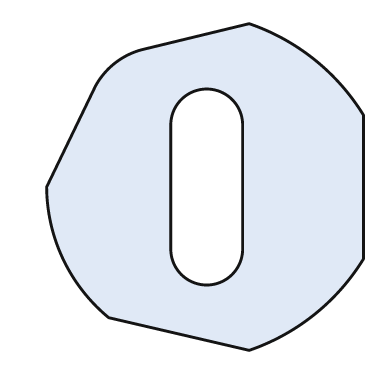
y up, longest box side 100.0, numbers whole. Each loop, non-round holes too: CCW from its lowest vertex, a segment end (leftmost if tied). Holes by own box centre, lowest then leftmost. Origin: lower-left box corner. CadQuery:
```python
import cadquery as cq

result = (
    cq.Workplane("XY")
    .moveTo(62.0, 0.0)
    .threePointArc((82.0, 11.0), (97.0, 28.0))
    .lineTo(97.0, 72.0)
    .threePointArc((82.0, 89.0), (62.0, 100.0))
    .lineTo(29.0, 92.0)
    .threePointArc((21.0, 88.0), (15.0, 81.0))
    .lineTo(0.0, 50.0)
    .threePointArc((5.0, 28.0), (19.0, 10.0))
    .close()
    .moveTo(38.0, 31.0)
    .threePointArc((49.0, 20.0), (60.0, 31.0))
    .lineTo(60.0, 69.0)
    .threePointArc((49.0, 80.0), (38.0, 69.0))
    .close()
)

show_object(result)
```